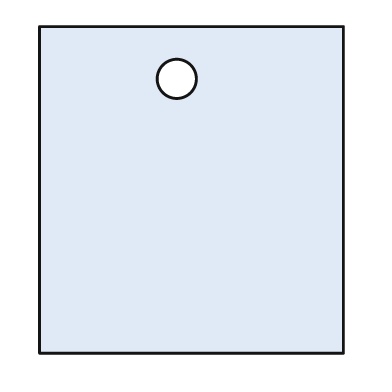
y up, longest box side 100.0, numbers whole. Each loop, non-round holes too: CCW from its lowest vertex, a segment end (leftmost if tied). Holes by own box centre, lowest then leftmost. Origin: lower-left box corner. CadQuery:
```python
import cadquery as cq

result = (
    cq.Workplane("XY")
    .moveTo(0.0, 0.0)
    .lineTo(93.0, 0.0)
    .lineTo(93.0, 100.0)
    .lineTo(0.0, 100.0)
    .close()
    .moveTo(42.0, 84.0)
    .circle(6.0)
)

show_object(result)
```